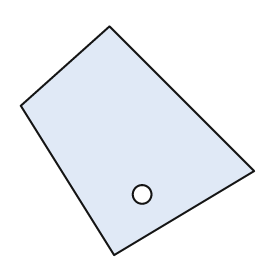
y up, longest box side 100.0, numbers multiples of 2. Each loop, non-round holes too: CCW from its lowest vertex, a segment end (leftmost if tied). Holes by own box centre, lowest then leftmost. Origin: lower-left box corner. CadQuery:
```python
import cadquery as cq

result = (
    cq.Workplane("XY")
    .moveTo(40.0, 0.0)
    .lineTo(100.0, 36.0)
    .lineTo(38.0, 98.0)
    .lineTo(0.0, 64.0)
    .close()
    .moveTo(52.0, 26.0)
    .circle(4.0)
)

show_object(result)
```